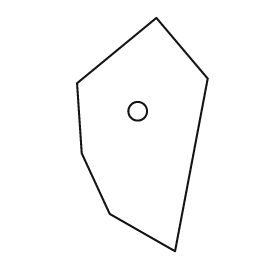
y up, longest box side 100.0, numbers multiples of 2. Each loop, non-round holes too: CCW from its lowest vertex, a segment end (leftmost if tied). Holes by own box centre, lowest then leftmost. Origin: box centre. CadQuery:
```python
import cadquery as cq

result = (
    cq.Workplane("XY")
    .moveTo(14.0, -50.0)
    .lineTo(28.0, 24.0)
    .lineTo(6.0, 50.0)
    .lineTo(-28.0, 22.0)
    .lineTo(-26.0, -8.0)
    .lineTo(-14.0, -34.0)
    .close()
    .moveTo(-2.0, 10.0)
    .circle(4.0)
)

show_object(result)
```